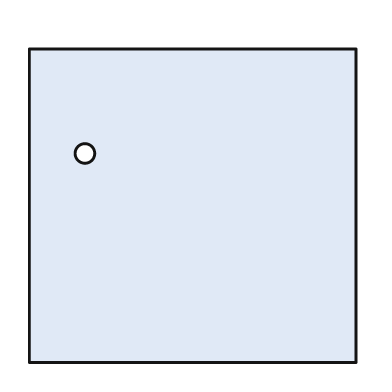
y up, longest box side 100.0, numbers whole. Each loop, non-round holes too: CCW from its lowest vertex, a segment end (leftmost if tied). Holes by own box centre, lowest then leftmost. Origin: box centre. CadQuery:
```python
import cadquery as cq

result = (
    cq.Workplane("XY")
    .moveTo(-50.0, -48.0)
    .lineTo(50.0, -48.0)
    .lineTo(50.0, 48.0)
    .lineTo(-50.0, 48.0)
    .close()
    .moveTo(-33.0, 16.0)
    .circle(3.0)
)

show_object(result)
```